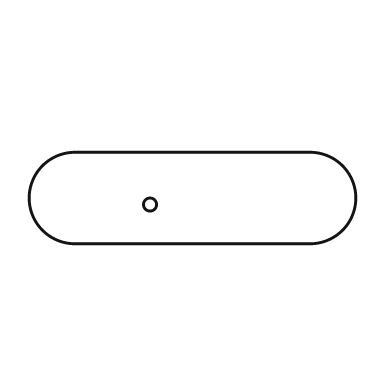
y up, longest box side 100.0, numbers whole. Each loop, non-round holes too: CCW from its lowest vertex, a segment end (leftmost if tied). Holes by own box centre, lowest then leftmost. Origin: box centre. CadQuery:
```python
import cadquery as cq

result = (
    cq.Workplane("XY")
    .moveTo(-36.0, -14.0)
    .lineTo(36.0, -14.0)
    .threePointArc((50.0, 0.0), (36.0, 14.0))
    .lineTo(-36.0, 14.0)
    .threePointArc((-50.0, 0.0), (-36.0, -14.0))
    .close()
    .moveTo(-13.0, -2.0)
    .circle(2.0)
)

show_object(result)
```